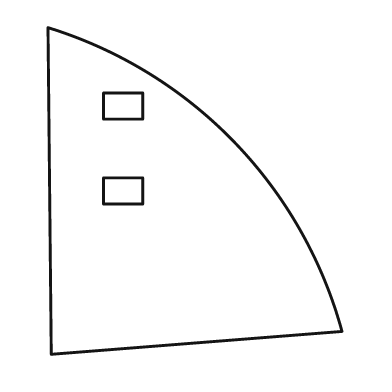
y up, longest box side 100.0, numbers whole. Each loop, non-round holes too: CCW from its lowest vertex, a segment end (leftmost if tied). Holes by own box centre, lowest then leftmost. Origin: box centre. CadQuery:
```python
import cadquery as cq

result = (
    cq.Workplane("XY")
    .moveTo(-44.0, -50.0)
    .lineTo(45.0, -43.0)
    .threePointArc((12.0, 15.0), (-45.0, 50.0))
    .close()
    .moveTo(-28.0, -4.0)
    .lineTo(-16.0, -4.0)
    .lineTo(-16.0, 4.0)
    .lineTo(-28.0, 4.0)
    .close()
    .moveTo(-28.0, 22.0)
    .lineTo(-16.0, 22.0)
    .lineTo(-16.0, 30.0)
    .lineTo(-28.0, 30.0)
    .close()
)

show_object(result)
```